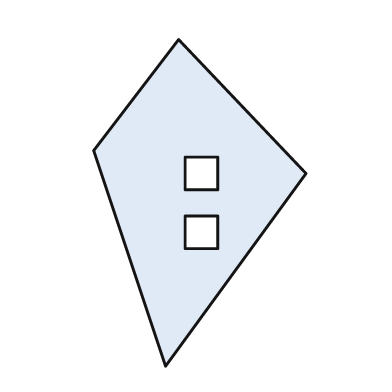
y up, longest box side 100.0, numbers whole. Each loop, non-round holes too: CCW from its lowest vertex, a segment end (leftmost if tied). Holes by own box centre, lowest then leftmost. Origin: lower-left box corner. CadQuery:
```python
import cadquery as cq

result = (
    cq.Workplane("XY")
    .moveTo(22.0, 0.0)
    .lineTo(65.0, 59.0)
    .lineTo(26.0, 100.0)
    .lineTo(0.0, 66.0)
    .close()
    .moveTo(28.0, 36.0)
    .lineTo(38.0, 36.0)
    .lineTo(38.0, 46.0)
    .lineTo(28.0, 46.0)
    .close()
    .moveTo(28.0, 54.0)
    .lineTo(38.0, 54.0)
    .lineTo(38.0, 64.0)
    .lineTo(28.0, 64.0)
    .close()
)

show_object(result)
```